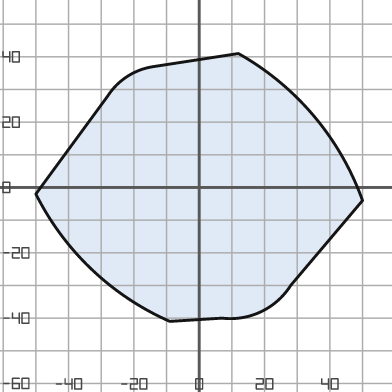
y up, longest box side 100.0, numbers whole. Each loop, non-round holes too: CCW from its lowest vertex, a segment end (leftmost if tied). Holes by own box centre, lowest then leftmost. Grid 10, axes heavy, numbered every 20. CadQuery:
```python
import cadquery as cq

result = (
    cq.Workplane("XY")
    .moveTo(-9.0, -41.0)
    .lineTo(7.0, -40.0)
    .threePointArc((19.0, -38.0), (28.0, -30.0))
    .lineTo(50.0, -4.0)
    .threePointArc((35.0, 22.0), (12.0, 41.0))
    .lineTo(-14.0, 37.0)
    .threePointArc((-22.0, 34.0), (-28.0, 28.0))
    .lineTo(-50.0, -2.0)
    .threePointArc((-33.0, -25.0), (-9.0, -41.0))
    .close()
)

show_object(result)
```